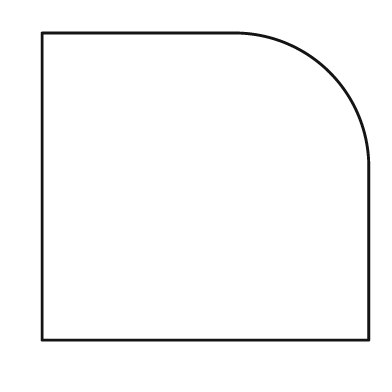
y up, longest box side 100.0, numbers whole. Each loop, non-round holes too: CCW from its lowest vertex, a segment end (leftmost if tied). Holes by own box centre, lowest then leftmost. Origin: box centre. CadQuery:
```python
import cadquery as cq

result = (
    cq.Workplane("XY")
    .moveTo(-50.0, -47.0)
    .lineTo(50.0, -47.0)
    .lineTo(50.0, 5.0)
    .threePointArc((38.0, 35.0), (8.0, 47.0))
    .lineTo(-50.0, 47.0)
    .close()
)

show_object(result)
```